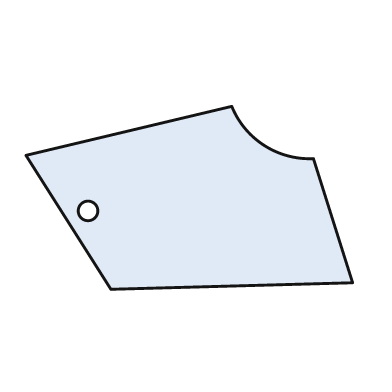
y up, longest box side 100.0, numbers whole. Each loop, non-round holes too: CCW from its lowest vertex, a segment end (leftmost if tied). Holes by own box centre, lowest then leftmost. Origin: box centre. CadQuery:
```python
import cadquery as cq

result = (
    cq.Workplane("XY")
    .moveTo(-24.0, -28.0)
    .lineTo(50.0, -26.0)
    .lineTo(38.0, 12.0)
    .threePointArc((23.0, 16.0), (13.0, 28.0))
    .lineTo(-50.0, 13.0)
    .close()
    .moveTo(-31.0, -4.0)
    .circle(3.0)
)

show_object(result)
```